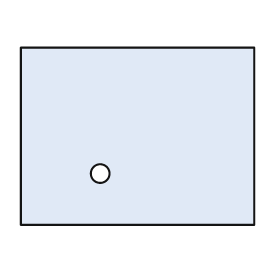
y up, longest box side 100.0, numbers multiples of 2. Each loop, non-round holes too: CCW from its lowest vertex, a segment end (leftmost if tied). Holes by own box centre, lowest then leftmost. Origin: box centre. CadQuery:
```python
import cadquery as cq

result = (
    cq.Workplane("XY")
    .moveTo(-50.0, -38.0)
    .lineTo(50.0, -38.0)
    .lineTo(50.0, 38.0)
    .lineTo(-50.0, 38.0)
    .close()
    .moveTo(-16.0, -16.0)
    .circle(4.0)
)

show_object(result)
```